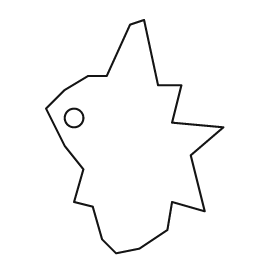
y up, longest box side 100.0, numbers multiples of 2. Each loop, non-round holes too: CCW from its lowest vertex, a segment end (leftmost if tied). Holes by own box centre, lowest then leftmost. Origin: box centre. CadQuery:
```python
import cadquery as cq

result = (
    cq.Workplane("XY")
    .moveTo(-8.0, -50.0)
    .lineTo(2.0, -48.0)
    .lineTo(14.0, -40.0)
    .lineTo(16.0, -28.0)
    .lineTo(30.0, -32.0)
    .lineTo(24.0, -8.0)
    .lineTo(38.0, 4.0)
    .lineTo(16.0, 6.0)
    .lineTo(20.0, 22.0)
    .lineTo(10.0, 22.0)
    .lineTo(4.0, 50.0)
    .lineTo(-2.0, 48.0)
    .lineTo(-12.0, 26.0)
    .lineTo(-20.0, 26.0)
    .lineTo(-30.0, 20.0)
    .lineTo(-38.0, 12.0)
    .lineTo(-30.0, -4.0)
    .lineTo(-22.0, -14.0)
    .lineTo(-26.0, -28.0)
    .lineTo(-18.0, -30.0)
    .lineTo(-14.0, -44.0)
    .close()
    .moveTo(-26.0, 8.0)
    .circle(4.0)
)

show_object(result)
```